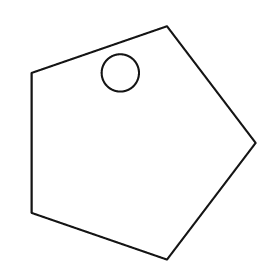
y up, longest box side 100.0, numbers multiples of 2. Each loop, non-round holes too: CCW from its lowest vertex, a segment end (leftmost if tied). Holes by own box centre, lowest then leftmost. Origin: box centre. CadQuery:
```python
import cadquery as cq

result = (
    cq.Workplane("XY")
    .moveTo(10.0, -50.0)
    .lineTo(48.0, 0.0)
    .lineTo(10.0, 50.0)
    .lineTo(-48.0, 30.0)
    .lineTo(-48.0, -30.0)
    .close()
    .moveTo(-10.0, 30.0)
    .circle(8.0)
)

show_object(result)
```